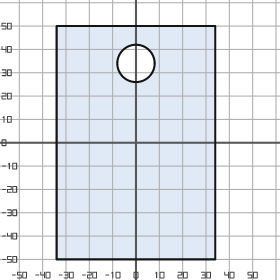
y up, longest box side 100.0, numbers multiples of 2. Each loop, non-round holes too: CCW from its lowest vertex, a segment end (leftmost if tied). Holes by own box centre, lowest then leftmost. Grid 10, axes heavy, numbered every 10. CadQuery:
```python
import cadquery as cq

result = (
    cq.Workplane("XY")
    .moveTo(-34.0, -50.0)
    .lineTo(34.0, -50.0)
    .lineTo(34.0, 50.0)
    .lineTo(-34.0, 50.0)
    .close()
    .moveTo(0.0, 34.0)
    .circle(8.0)
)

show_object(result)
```